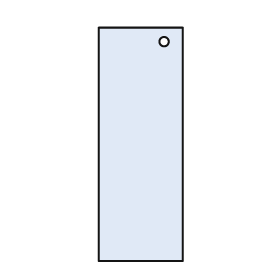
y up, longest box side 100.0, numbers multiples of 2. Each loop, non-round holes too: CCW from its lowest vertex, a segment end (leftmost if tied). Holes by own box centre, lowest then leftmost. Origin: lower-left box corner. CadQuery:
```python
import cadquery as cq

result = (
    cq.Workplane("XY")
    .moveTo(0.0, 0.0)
    .lineTo(36.0, 0.0)
    .lineTo(36.0, 100.0)
    .lineTo(0.0, 100.0)
    .close()
    .moveTo(28.0, 94.0)
    .circle(2.0)
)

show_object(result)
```